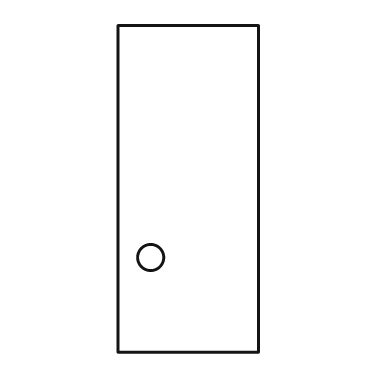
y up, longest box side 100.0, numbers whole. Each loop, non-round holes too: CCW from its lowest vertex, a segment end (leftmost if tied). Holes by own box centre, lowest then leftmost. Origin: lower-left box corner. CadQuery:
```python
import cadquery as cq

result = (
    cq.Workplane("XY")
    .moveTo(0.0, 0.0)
    .lineTo(43.0, 0.0)
    .lineTo(43.0, 100.0)
    .lineTo(0.0, 100.0)
    .close()
    .moveTo(10.0, 29.0)
    .circle(4.0)
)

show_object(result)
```